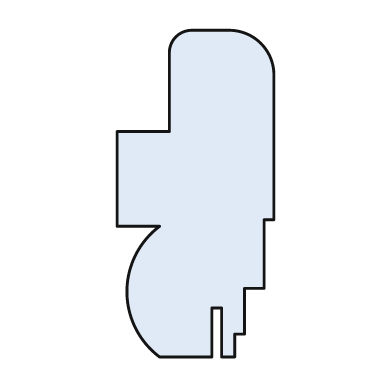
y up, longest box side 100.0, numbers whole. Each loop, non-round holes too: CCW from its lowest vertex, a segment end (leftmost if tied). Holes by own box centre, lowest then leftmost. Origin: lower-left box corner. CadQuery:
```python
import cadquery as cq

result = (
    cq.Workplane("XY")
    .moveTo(13.0, 0.0)
    .lineTo(29.0, 0.0)
    .lineTo(29.0, 15.0)
    .lineTo(32.0, 15.0)
    .lineTo(32.0, 0.0)
    .lineTo(36.0, 0.0)
    .lineTo(36.0, 7.0)
    .lineTo(39.0, 7.0)
    .lineTo(39.0, 21.0)
    .lineTo(45.0, 21.0)
    .lineTo(45.0, 42.0)
    .lineTo(48.0, 42.0)
    .lineTo(48.0, 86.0)
    .threePointArc((44.0, 96.0), (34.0, 100.0))
    .lineTo(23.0, 100.0)
    .threePointArc((18.0, 98.0), (16.0, 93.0))
    .lineTo(16.0, 69.0)
    .lineTo(0.0, 69.0)
    .lineTo(0.0, 40.0)
    .lineTo(13.0, 40.0)
    .threePointArc((3.0, 20.0), (13.0, 0.0))
    .close()
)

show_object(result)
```